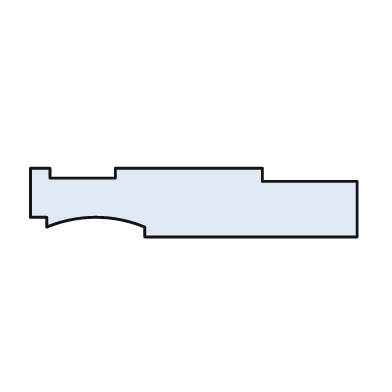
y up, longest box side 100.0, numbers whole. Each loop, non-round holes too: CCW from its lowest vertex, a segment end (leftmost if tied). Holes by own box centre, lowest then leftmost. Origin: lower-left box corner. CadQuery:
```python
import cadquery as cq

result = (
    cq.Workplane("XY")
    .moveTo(35.0, 0.0)
    .lineTo(100.0, 0.0)
    .lineTo(100.0, 17.0)
    .lineTo(71.0, 17.0)
    .lineTo(71.0, 21.0)
    .lineTo(26.0, 21.0)
    .lineTo(26.0, 18.0)
    .lineTo(6.0, 18.0)
    .lineTo(6.0, 21.0)
    .lineTo(0.0, 21.0)
    .lineTo(0.0, 6.0)
    .lineTo(5.0, 6.0)
    .lineTo(5.0, 3.0)
    .threePointArc((20.0, 6.0), (35.0, 3.0))
    .close()
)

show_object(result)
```